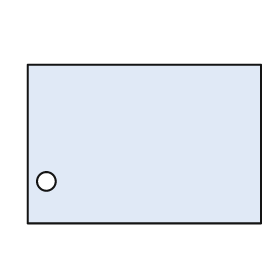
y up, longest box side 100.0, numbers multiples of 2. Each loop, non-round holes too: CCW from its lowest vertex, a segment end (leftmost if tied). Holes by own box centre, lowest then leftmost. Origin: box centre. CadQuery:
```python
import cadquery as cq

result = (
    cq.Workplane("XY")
    .moveTo(-50.0, -34.0)
    .lineTo(50.0, -34.0)
    .lineTo(50.0, 34.0)
    .lineTo(-50.0, 34.0)
    .close()
    .moveTo(-42.0, -16.0)
    .circle(4.0)
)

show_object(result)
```